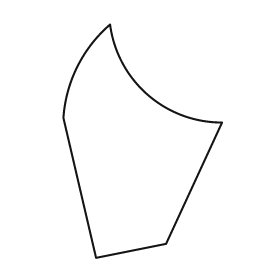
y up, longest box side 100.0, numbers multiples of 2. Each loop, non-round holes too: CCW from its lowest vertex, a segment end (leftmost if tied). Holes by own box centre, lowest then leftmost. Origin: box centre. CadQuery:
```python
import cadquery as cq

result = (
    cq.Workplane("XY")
    .moveTo(-20.0, -50.0)
    .lineTo(10.0, -44.0)
    .lineTo(34.0, 8.0)
    .threePointArc((2.0, 20.0), (-14.0, 50.0))
    .threePointArc((-28.0, 32.0), (-34.0, 10.0))
    .close()
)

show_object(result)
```